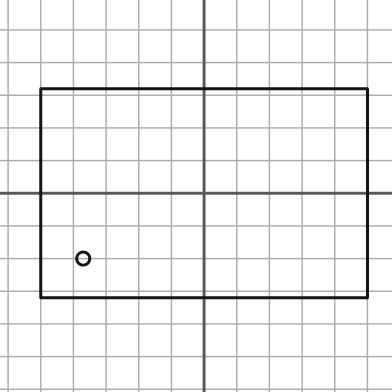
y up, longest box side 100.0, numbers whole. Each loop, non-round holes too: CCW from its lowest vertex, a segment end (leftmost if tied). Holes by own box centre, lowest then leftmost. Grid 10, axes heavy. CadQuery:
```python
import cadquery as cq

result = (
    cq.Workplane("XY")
    .moveTo(-50.0, -32.0)
    .lineTo(50.0, -32.0)
    .lineTo(50.0, 32.0)
    .lineTo(-50.0, 32.0)
    .close()
    .moveTo(-37.0, -20.0)
    .circle(2.0)
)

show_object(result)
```